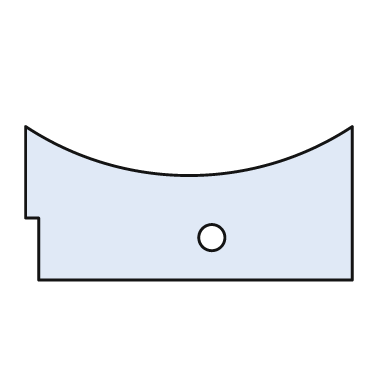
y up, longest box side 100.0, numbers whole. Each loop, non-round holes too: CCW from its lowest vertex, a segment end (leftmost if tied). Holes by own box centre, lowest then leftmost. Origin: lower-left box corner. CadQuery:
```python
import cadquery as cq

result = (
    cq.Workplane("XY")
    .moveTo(4.0, 0.0)
    .lineTo(100.0, 0.0)
    .lineTo(100.0, 47.0)
    .threePointArc((50.0, 32.0), (0.0, 47.0))
    .lineTo(0.0, 19.0)
    .lineTo(4.0, 19.0)
    .close()
    .moveTo(57.0, 13.0)
    .circle(4.0)
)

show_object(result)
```